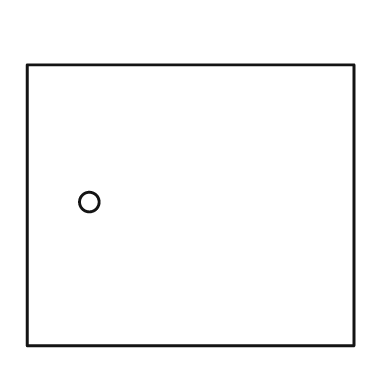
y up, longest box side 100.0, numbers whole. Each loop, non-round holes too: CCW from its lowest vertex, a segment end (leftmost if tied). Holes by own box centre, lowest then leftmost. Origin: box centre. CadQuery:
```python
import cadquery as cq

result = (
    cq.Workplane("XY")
    .moveTo(-50.0, -43.0)
    .lineTo(50.0, -43.0)
    .lineTo(50.0, 43.0)
    .lineTo(-50.0, 43.0)
    .close()
    .moveTo(-31.0, 1.0)
    .circle(3.0)
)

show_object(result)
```